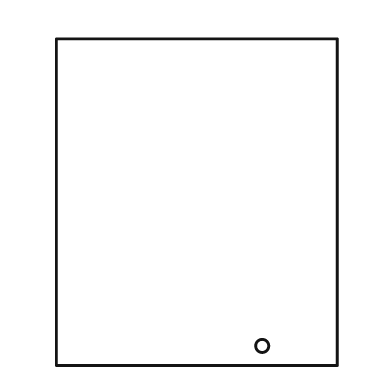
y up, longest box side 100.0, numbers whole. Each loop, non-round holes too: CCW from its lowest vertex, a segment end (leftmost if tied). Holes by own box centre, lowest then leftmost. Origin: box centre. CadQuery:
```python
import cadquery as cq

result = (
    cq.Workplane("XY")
    .moveTo(-43.0, -50.0)
    .lineTo(43.0, -50.0)
    .lineTo(43.0, 50.0)
    .lineTo(-43.0, 50.0)
    .close()
    .moveTo(20.0, -44.0)
    .circle(2.0)
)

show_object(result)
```